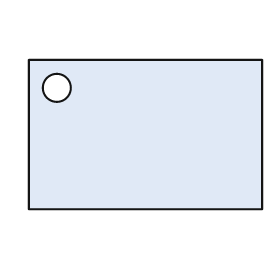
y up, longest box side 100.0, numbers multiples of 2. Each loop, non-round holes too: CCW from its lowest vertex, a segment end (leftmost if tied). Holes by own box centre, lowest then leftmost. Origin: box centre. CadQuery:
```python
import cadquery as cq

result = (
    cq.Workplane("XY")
    .moveTo(-50.0, -32.0)
    .lineTo(50.0, -32.0)
    .lineTo(50.0, 32.0)
    .lineTo(-50.0, 32.0)
    .close()
    .moveTo(-38.0, 20.0)
    .circle(6.0)
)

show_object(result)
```